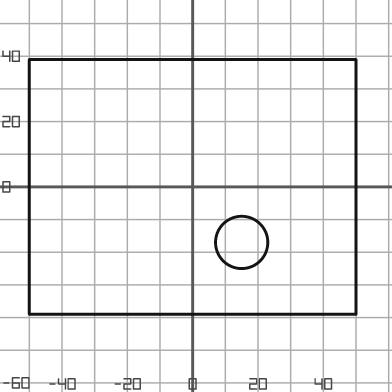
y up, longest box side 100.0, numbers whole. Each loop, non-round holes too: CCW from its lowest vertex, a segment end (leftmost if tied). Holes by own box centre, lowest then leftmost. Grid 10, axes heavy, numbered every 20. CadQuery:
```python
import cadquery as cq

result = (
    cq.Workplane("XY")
    .moveTo(-50.0, -39.0)
    .lineTo(50.0, -39.0)
    .lineTo(50.0, 39.0)
    .lineTo(-50.0, 39.0)
    .close()
    .moveTo(15.0, -17.0)
    .circle(8.0)
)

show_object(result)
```